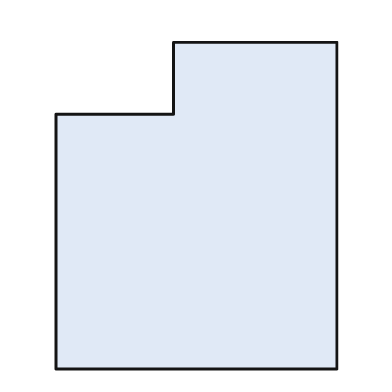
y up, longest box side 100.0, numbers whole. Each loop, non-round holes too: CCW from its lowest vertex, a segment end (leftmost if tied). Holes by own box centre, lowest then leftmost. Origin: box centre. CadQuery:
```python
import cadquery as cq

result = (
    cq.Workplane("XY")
    .moveTo(-43.0, -50.0)
    .lineTo(43.0, -50.0)
    .lineTo(43.0, 50.0)
    .lineTo(-7.0, 50.0)
    .lineTo(-7.0, 28.0)
    .lineTo(-43.0, 28.0)
    .close()
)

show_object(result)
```